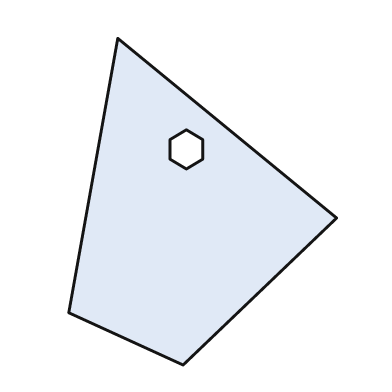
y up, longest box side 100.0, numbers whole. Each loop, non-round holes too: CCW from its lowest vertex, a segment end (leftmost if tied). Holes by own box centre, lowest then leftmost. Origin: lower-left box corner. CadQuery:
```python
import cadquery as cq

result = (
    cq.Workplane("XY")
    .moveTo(35.0, 0.0)
    .lineTo(82.0, 45.0)
    .lineTo(15.0, 100.0)
    .lineTo(0.0, 16.0)
    .close()
    .moveTo(36.0, 60.0)
    .lineTo(41.0, 63.0)
    .lineTo(41.0, 69.0)
    .lineTo(36.0, 72.0)
    .lineTo(31.0, 69.0)
    .lineTo(31.0, 63.0)
    .close()
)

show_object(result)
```